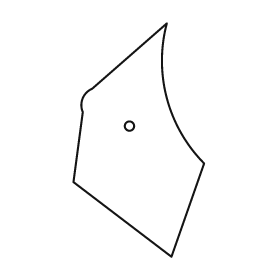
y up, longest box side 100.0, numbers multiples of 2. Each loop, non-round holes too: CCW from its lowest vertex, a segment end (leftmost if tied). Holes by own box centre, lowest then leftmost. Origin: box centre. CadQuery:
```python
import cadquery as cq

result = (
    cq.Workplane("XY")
    .moveTo(14.0, -50.0)
    .lineTo(28.0, -10.0)
    .threePointArc((12.0, 18.0), (12.0, 50.0))
    .lineTo(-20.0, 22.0)
    .threePointArc((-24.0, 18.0), (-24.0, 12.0))
    .lineTo(-28.0, -18.0)
    .close()
    .moveTo(-4.0, 6.0)
    .circle(2.0)
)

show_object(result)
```